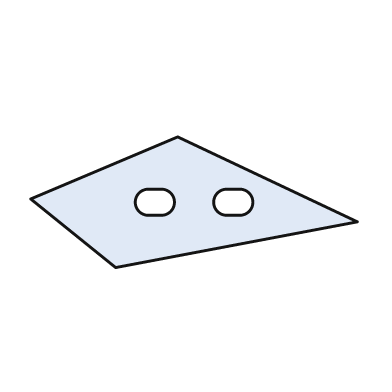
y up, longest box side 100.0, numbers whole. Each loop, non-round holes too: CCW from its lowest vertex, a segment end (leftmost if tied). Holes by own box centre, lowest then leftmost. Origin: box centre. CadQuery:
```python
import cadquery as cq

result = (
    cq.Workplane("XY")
    .moveTo(-24.0, -20.0)
    .lineTo(50.0, -6.0)
    .lineTo(-5.0, 20.0)
    .lineTo(-50.0, 1.0)
    .close()
    .moveTo(-14.0, -4.0)
    .lineTo(-10.0, -4.0)
    .threePointArc((-6.0, 0.0), (-10.0, 4.0))
    .lineTo(-14.0, 4.0)
    .threePointArc((-18.0, 0.0), (-14.0, -4.0))
    .close()
    .moveTo(10.0, -4.0)
    .lineTo(14.0, -4.0)
    .threePointArc((18.0, 0.0), (14.0, 4.0))
    .lineTo(10.0, 4.0)
    .threePointArc((6.0, 0.0), (10.0, -4.0))
    .close()
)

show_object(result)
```